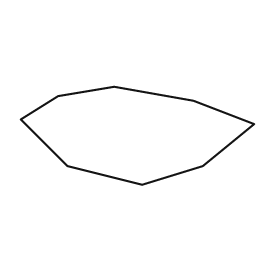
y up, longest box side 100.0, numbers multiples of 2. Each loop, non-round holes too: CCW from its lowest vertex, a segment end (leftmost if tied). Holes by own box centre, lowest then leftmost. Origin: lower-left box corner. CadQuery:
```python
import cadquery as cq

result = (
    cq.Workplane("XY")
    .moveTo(52.0, 0.0)
    .lineTo(78.0, 8.0)
    .lineTo(100.0, 26.0)
    .lineTo(74.0, 36.0)
    .lineTo(40.0, 42.0)
    .lineTo(16.0, 38.0)
    .lineTo(0.0, 28.0)
    .lineTo(20.0, 8.0)
    .close()
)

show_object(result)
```